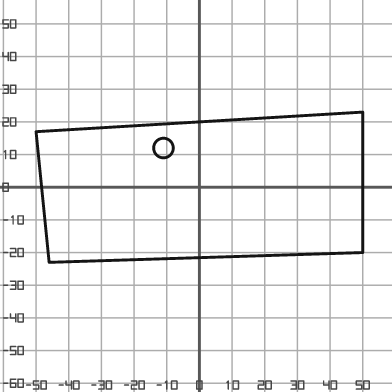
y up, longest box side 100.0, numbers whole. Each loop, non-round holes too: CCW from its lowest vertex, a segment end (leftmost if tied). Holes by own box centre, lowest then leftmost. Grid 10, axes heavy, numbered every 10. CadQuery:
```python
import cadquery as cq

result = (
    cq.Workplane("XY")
    .moveTo(-46.0, -23.0)
    .lineTo(50.0, -20.0)
    .lineTo(50.0, 23.0)
    .lineTo(-50.0, 17.0)
    .close()
    .moveTo(-11.0, 12.0)
    .circle(3.0)
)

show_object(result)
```